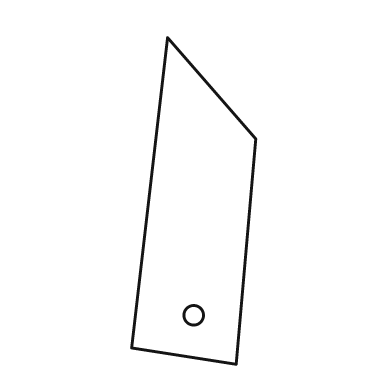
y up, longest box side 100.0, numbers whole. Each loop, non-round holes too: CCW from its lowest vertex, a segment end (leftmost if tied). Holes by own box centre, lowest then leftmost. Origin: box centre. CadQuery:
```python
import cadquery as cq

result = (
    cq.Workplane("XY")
    .moveTo(13.0, -50.0)
    .lineTo(19.0, 19.0)
    .lineTo(-8.0, 50.0)
    .lineTo(-19.0, -45.0)
    .close()
    .moveTo(0.0, -35.0)
    .circle(3.0)
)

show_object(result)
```